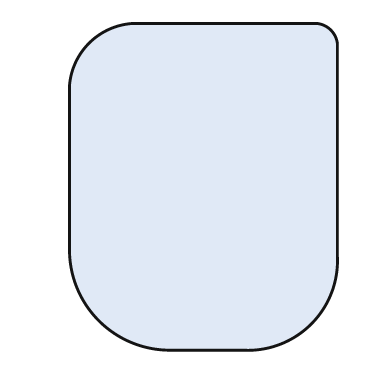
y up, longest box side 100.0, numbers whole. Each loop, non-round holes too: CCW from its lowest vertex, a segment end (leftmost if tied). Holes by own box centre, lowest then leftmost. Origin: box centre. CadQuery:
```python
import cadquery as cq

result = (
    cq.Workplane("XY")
    .moveTo(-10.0, -50.0)
    .lineTo(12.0, -50.0)
    .threePointArc((33.0, -42.0), (41.0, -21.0))
    .lineTo(41.0, 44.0)
    .threePointArc((39.0, 48.0), (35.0, 50.0))
    .lineTo(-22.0, 50.0)
    .threePointArc((-35.0, 44.0), (-41.0, 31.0))
    .lineTo(-41.0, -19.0)
    .threePointArc((-32.0, -41.0), (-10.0, -50.0))
    .close()
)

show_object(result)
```